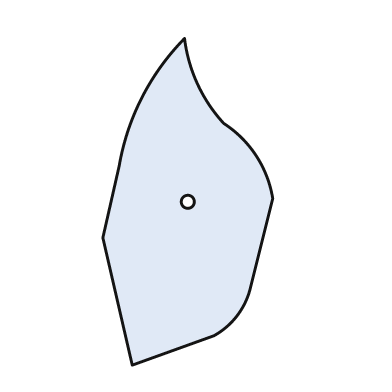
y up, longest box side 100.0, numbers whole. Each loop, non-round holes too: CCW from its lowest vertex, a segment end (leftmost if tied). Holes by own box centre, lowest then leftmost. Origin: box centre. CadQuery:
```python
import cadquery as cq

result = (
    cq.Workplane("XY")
    .moveTo(-17.0, -50.0)
    .lineTo(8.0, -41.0)
    .threePointArc((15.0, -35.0), (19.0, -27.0))
    .lineTo(26.0, 1.0)
    .threePointArc((21.0, 14.0), (11.0, 24.0))
    .threePointArc((3.0, 36.0), (-1.0, 50.0))
    .threePointArc((-14.0, 32.0), (-21.0, 11.0))
    .lineTo(-26.0, -11.0)
    .close()
    .moveTo(0.0, 0.0)
    .circle(2.0)
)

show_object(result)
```